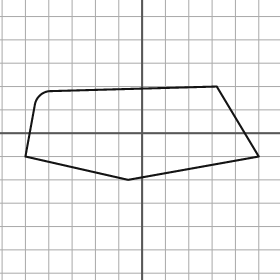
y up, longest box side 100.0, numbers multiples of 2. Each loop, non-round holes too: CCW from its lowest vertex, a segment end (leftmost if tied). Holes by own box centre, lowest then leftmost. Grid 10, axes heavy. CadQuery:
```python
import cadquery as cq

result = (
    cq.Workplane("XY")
    .moveTo(-6.0, -20.0)
    .lineTo(50.0, -10.0)
    .lineTo(32.0, 20.0)
    .lineTo(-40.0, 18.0)
    .threePointArc((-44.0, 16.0), (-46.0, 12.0))
    .lineTo(-50.0, -10.0)
    .close()
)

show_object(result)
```